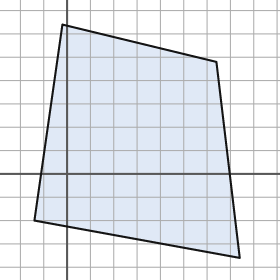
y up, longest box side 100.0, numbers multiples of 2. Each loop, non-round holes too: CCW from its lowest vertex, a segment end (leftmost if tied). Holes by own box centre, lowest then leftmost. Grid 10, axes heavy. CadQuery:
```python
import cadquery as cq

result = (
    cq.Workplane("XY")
    .moveTo(74.0, -36.0)
    .lineTo(64.0, 48.0)
    .lineTo(-2.0, 64.0)
    .lineTo(-14.0, -20.0)
    .close()
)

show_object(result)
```